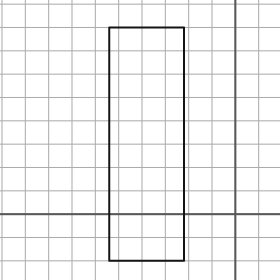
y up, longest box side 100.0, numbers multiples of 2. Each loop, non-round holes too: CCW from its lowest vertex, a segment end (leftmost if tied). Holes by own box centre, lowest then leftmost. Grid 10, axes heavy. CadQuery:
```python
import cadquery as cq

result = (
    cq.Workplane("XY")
    .moveTo(-54.0, -20.0)
    .lineTo(-22.0, -20.0)
    .lineTo(-22.0, 80.0)
    .lineTo(-54.0, 80.0)
    .close()
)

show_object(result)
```